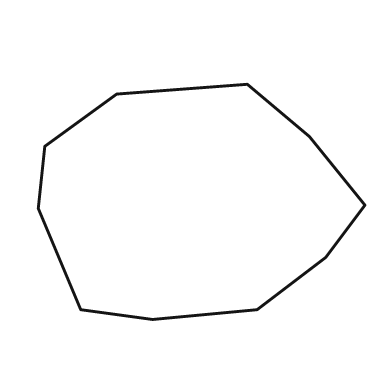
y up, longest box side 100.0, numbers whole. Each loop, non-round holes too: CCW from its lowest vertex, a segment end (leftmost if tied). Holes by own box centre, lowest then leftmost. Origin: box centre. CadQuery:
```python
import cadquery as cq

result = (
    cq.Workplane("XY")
    .moveTo(-15.0, -36.0)
    .lineTo(17.0, -33.0)
    .lineTo(38.0, -17.0)
    .lineTo(50.0, -1.0)
    .lineTo(33.0, 20.0)
    .lineTo(14.0, 36.0)
    .lineTo(-26.0, 33.0)
    .lineTo(-48.0, 17.0)
    .lineTo(-50.0, -2.0)
    .lineTo(-37.0, -33.0)
    .close()
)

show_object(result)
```